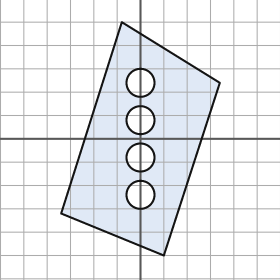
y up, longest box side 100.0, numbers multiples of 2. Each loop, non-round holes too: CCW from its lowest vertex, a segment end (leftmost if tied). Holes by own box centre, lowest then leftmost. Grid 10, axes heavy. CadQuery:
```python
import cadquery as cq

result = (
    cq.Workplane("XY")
    .moveTo(10.0, -50.0)
    .lineTo(34.0, 24.0)
    .lineTo(-8.0, 50.0)
    .lineTo(-34.0, -32.0)
    .close()
    .moveTo(0.0, -24.0)
    .circle(6.0)
    .moveTo(0.0, -8.0)
    .circle(6.0)
    .moveTo(0.0, 8.0)
    .circle(6.0)
    .moveTo(0.0, 24.0)
    .circle(6.0)
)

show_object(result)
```